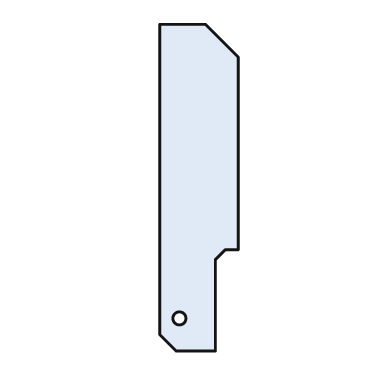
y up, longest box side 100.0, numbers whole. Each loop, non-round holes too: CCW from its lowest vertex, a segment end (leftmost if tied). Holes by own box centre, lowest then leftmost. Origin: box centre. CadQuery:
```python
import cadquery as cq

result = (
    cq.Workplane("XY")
    .moveTo(-7.0, -50.0)
    .lineTo(5.0, -50.0)
    .lineTo(5.0, -22.0)
    .lineTo(8.0, -19.0)
    .lineTo(12.0, -19.0)
    .lineTo(12.0, 40.0)
    .lineTo(2.0, 50.0)
    .lineTo(-12.0, 50.0)
    .lineTo(-12.0, -45.0)
    .close()
    .moveTo(-6.0, -40.0)
    .circle(2.0)
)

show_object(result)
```